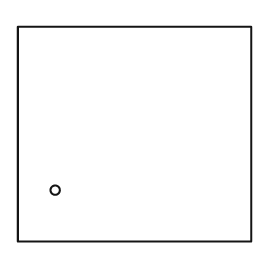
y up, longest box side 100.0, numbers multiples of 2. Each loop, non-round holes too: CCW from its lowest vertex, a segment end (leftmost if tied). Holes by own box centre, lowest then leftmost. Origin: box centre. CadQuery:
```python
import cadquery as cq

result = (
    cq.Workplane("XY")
    .moveTo(-50.0, -46.0)
    .lineTo(50.0, -46.0)
    .lineTo(50.0, 46.0)
    .lineTo(-50.0, 46.0)
    .close()
    .moveTo(-34.0, -24.0)
    .circle(2.0)
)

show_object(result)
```